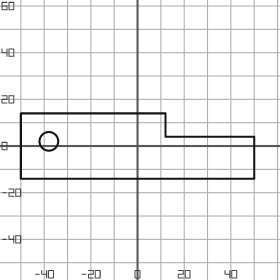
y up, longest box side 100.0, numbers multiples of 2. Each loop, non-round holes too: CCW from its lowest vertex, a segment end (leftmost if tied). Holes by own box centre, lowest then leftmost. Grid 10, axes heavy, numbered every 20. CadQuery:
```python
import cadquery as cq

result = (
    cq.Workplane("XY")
    .moveTo(-50.0, -14.0)
    .lineTo(50.0, -14.0)
    .lineTo(50.0, 4.0)
    .lineTo(12.0, 4.0)
    .lineTo(12.0, 14.0)
    .lineTo(-50.0, 14.0)
    .close()
    .moveTo(-38.0, 2.0)
    .circle(4.0)
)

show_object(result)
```